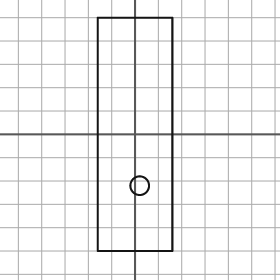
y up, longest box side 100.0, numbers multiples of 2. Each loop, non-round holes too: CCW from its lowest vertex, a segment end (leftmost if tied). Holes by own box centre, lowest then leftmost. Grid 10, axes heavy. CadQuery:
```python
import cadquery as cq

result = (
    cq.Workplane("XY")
    .moveTo(-16.0, -50.0)
    .lineTo(16.0, -50.0)
    .lineTo(16.0, 50.0)
    .lineTo(-16.0, 50.0)
    .close()
    .moveTo(2.0, -22.0)
    .circle(4.0)
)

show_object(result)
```